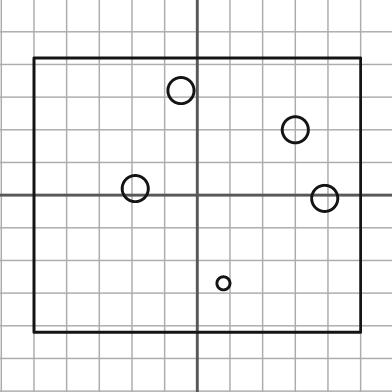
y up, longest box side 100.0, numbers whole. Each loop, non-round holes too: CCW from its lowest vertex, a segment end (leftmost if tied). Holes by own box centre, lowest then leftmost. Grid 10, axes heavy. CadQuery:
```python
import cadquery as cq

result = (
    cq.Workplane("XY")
    .moveTo(-50.0, -42.0)
    .lineTo(50.0, -42.0)
    .lineTo(50.0, 42.0)
    .lineTo(-50.0, 42.0)
    .close()
    .moveTo(8.0, -27.0)
    .circle(2.0)
    .moveTo(39.0, -1.0)
    .circle(4.0)
    .moveTo(-19.0, 2.0)
    .circle(4.0)
    .moveTo(30.0, 20.0)
    .circle(4.0)
    .moveTo(-5.0, 32.0)
    .circle(4.0)
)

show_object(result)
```